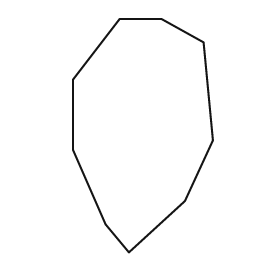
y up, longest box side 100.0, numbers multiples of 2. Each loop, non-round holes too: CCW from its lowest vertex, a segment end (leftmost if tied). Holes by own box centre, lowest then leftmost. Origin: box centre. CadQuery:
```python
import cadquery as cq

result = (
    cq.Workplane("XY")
    .moveTo(-6.0, -50.0)
    .lineTo(18.0, -28.0)
    .lineTo(30.0, -2.0)
    .lineTo(26.0, 40.0)
    .lineTo(8.0, 50.0)
    .lineTo(-10.0, 50.0)
    .lineTo(-30.0, 24.0)
    .lineTo(-30.0, -6.0)
    .lineTo(-16.0, -38.0)
    .close()
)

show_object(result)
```